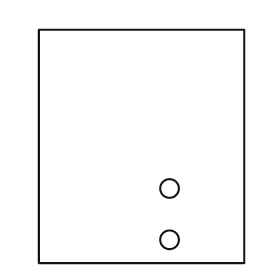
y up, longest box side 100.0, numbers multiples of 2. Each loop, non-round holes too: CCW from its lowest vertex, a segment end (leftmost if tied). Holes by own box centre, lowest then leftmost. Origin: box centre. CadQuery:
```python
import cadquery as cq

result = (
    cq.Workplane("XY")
    .moveTo(-44.0, -50.0)
    .lineTo(44.0, -50.0)
    .lineTo(44.0, 50.0)
    .lineTo(-44.0, 50.0)
    .close()
    .moveTo(12.0, -40.0)
    .circle(4.0)
    .moveTo(12.0, -18.0)
    .circle(4.0)
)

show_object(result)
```